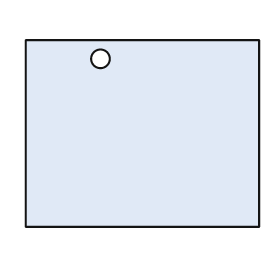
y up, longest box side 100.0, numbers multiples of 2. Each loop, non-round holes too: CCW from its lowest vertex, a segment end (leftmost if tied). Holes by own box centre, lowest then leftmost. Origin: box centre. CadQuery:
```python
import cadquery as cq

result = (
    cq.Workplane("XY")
    .moveTo(-50.0, -40.0)
    .lineTo(50.0, -40.0)
    .lineTo(50.0, 40.0)
    .lineTo(-50.0, 40.0)
    .close()
    .moveTo(-18.0, 32.0)
    .circle(4.0)
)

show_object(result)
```